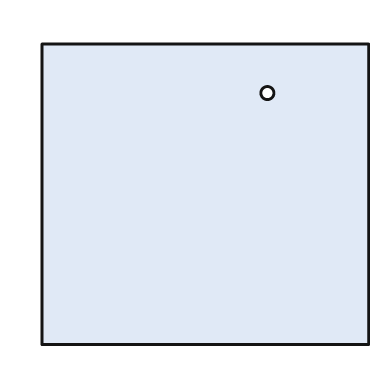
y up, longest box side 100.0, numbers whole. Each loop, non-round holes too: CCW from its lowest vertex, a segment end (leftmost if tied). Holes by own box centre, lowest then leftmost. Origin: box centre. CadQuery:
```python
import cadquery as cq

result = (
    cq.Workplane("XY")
    .moveTo(-50.0, -46.0)
    .lineTo(50.0, -46.0)
    .lineTo(50.0, 46.0)
    .lineTo(-50.0, 46.0)
    .close()
    .moveTo(19.0, 31.0)
    .circle(2.0)
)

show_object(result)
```